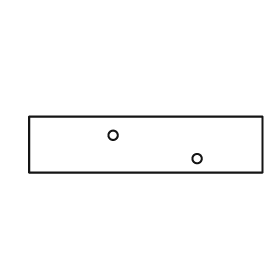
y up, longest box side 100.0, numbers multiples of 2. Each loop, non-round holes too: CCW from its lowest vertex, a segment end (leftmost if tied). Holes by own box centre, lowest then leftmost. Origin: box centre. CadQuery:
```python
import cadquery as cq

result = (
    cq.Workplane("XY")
    .moveTo(-50.0, -12.0)
    .lineTo(50.0, -12.0)
    .lineTo(50.0, 12.0)
    .lineTo(-50.0, 12.0)
    .close()
    .moveTo(22.0, -6.0)
    .circle(2.0)
    .moveTo(-14.0, 4.0)
    .circle(2.0)
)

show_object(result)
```